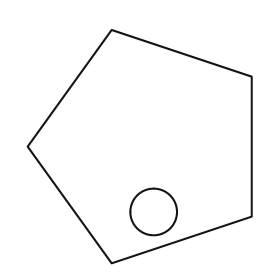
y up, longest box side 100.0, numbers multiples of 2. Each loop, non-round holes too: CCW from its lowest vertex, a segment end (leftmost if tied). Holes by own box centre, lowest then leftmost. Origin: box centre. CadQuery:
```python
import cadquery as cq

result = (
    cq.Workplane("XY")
    .moveTo(-12.0, -50.0)
    .lineTo(48.0, -30.0)
    .lineTo(48.0, 30.0)
    .lineTo(-12.0, 50.0)
    .lineTo(-48.0, 0.0)
    .close()
    .moveTo(6.0, -28.0)
    .circle(10.0)
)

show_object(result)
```